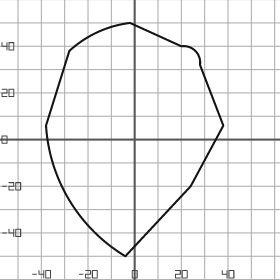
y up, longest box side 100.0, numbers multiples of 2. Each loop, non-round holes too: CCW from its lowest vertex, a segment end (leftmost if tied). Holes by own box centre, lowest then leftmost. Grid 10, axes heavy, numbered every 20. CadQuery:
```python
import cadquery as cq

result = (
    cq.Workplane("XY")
    .moveTo(-4.0, -50.0)
    .lineTo(24.0, -20.0)
    .lineTo(38.0, 6.0)
    .lineTo(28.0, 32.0)
    .threePointArc((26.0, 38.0), (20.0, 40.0))
    .lineTo(-2.0, 50.0)
    .threePointArc((-16.0, 46.0), (-28.0, 38.0))
    .lineTo(-38.0, 6.0)
    .threePointArc((-28.0, -26.0), (-4.0, -50.0))
    .close()
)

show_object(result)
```